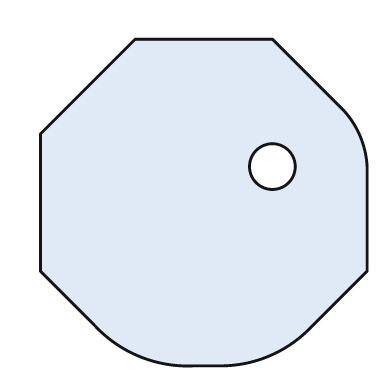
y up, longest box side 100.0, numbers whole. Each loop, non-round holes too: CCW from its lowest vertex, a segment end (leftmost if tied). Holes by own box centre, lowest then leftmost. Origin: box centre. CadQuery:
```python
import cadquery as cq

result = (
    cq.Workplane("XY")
    .moveTo(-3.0, -50.0)
    .lineTo(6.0, -50.0)
    .threePointArc((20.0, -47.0), (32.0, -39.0))
    .lineTo(50.0, -21.0)
    .lineTo(50.0, 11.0)
    .threePointArc((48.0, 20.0), (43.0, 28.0))
    .lineTo(21.0, 50.0)
    .lineTo(-21.0, 50.0)
    .lineTo(-50.0, 21.0)
    .lineTo(-50.0, -21.0)
    .lineTo(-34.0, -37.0)
    .threePointArc((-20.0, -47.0), (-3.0, -50.0))
    .close()
    .moveTo(21.0, 11.0)
    .circle(7.0)
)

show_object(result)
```